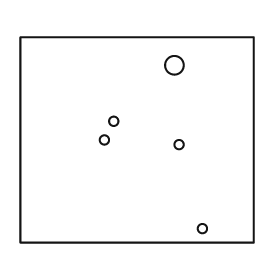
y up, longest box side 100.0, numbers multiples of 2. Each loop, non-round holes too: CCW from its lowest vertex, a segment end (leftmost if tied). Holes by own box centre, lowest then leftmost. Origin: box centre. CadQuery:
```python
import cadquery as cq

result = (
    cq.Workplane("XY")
    .moveTo(-50.0, -44.0)
    .lineTo(50.0, -44.0)
    .lineTo(50.0, 44.0)
    .lineTo(-50.0, 44.0)
    .close()
    .moveTo(28.0, -38.0)
    .circle(2.0)
    .moveTo(18.0, -2.0)
    .circle(2.0)
    .moveTo(-14.0, 0.0)
    .circle(2.0)
    .moveTo(-10.0, 8.0)
    .circle(2.0)
    .moveTo(16.0, 32.0)
    .circle(4.0)
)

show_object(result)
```